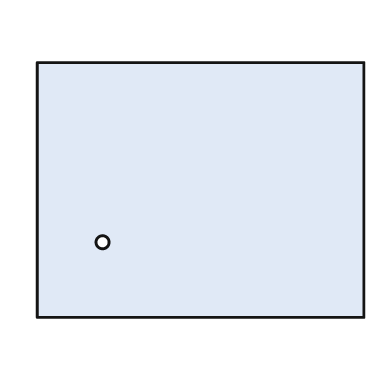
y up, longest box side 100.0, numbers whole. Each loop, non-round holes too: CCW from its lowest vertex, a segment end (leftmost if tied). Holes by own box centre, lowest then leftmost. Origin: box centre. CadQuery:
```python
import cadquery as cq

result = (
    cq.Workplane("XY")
    .moveTo(-50.0, -39.0)
    .lineTo(50.0, -39.0)
    .lineTo(50.0, 39.0)
    .lineTo(-50.0, 39.0)
    .close()
    .moveTo(-30.0, -16.0)
    .circle(2.0)
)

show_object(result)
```